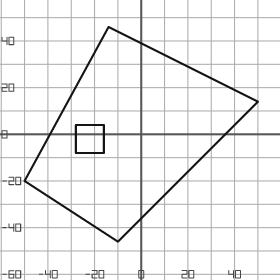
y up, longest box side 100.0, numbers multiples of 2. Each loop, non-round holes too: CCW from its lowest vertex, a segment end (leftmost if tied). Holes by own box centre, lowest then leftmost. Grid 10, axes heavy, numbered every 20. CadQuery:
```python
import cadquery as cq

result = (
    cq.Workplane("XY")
    .moveTo(-10.0, -46.0)
    .lineTo(50.0, 14.0)
    .lineTo(-14.0, 46.0)
    .lineTo(-50.0, -20.0)
    .close()
    .moveTo(-28.0, -8.0)
    .lineTo(-16.0, -8.0)
    .lineTo(-16.0, 4.0)
    .lineTo(-28.0, 4.0)
    .close()
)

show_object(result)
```